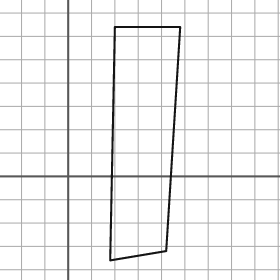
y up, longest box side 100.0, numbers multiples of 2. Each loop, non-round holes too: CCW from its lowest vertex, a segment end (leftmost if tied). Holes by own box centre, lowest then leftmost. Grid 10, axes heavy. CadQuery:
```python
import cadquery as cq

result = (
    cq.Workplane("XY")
    .moveTo(18.0, -36.0)
    .lineTo(42.0, -32.0)
    .lineTo(48.0, 64.0)
    .lineTo(20.0, 64.0)
    .close()
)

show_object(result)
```